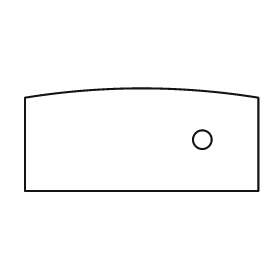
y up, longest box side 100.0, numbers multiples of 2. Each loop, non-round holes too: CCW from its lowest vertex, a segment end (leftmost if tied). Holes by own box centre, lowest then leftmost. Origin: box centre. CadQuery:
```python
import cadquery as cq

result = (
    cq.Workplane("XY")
    .moveTo(-50.0, -22.0)
    .lineTo(50.0, -22.0)
    .lineTo(50.0, 18.0)
    .threePointArc((0.0, 22.0), (-50.0, 18.0))
    .close()
    .moveTo(26.0, 0.0)
    .circle(4.0)
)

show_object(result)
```